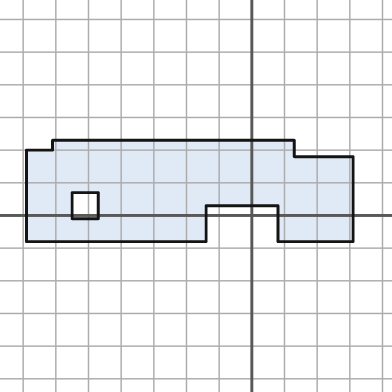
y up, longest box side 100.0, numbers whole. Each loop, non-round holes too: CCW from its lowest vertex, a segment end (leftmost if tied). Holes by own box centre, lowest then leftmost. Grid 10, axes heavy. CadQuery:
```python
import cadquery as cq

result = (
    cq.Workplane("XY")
    .moveTo(-69.0, -8.0)
    .lineTo(-14.0, -8.0)
    .lineTo(-14.0, 3.0)
    .lineTo(8.0, 3.0)
    .lineTo(8.0, -8.0)
    .lineTo(31.0, -8.0)
    .lineTo(31.0, 18.0)
    .lineTo(13.0, 18.0)
    .lineTo(13.0, 23.0)
    .lineTo(-61.0, 23.0)
    .lineTo(-61.0, 20.0)
    .lineTo(-69.0, 20.0)
    .close()
    .moveTo(-55.0, -1.0)
    .lineTo(-47.0, -1.0)
    .lineTo(-47.0, 7.0)
    .lineTo(-55.0, 7.0)
    .close()
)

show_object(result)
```